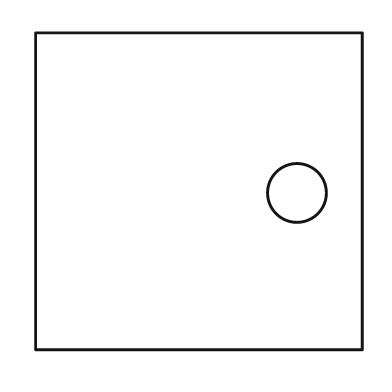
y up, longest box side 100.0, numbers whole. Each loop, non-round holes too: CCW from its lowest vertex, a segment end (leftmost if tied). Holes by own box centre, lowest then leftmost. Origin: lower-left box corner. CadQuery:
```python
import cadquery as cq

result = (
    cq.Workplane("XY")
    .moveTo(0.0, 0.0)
    .lineTo(100.0, 0.0)
    .lineTo(100.0, 97.0)
    .lineTo(0.0, 97.0)
    .close()
    .moveTo(80.0, 48.0)
    .circle(9.0)
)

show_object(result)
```